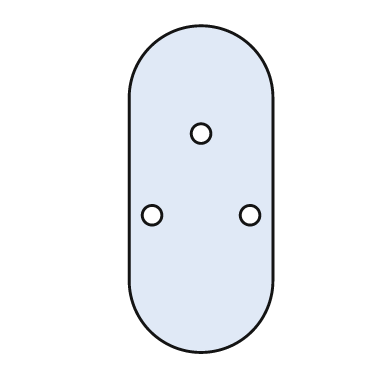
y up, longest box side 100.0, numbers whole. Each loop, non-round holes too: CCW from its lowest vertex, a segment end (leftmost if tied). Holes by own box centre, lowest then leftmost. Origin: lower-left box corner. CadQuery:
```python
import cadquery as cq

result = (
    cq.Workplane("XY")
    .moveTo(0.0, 22.0)
    .threePointArc((22.0, 0.0), (44.0, 22.0))
    .lineTo(44.0, 78.0)
    .threePointArc((22.0, 100.0), (0.0, 78.0))
    .close()
    .moveTo(7.0, 42.0)
    .circle(3.0)
    .moveTo(37.0, 42.0)
    .circle(3.0)
    .moveTo(22.0, 67.0)
    .circle(3.0)
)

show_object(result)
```